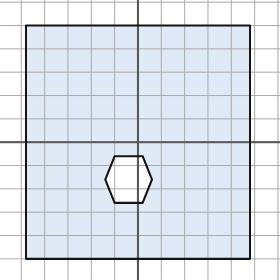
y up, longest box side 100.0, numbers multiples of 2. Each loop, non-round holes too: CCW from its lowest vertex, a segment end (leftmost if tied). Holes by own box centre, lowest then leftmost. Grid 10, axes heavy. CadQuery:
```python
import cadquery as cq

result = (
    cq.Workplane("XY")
    .moveTo(-48.0, -50.0)
    .lineTo(48.0, -50.0)
    .lineTo(48.0, 50.0)
    .lineTo(-48.0, 50.0)
    .close()
    .moveTo(-10.0, -26.0)
    .lineTo(2.0, -26.0)
    .lineTo(6.0, -16.0)
    .lineTo(2.0, -6.0)
    .lineTo(-10.0, -6.0)
    .lineTo(-14.0, -16.0)
    .close()
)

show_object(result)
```